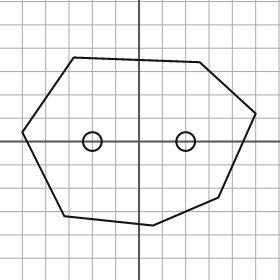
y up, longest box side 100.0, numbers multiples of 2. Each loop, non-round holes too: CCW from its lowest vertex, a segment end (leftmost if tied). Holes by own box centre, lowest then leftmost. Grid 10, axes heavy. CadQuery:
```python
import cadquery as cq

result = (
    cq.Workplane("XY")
    .moveTo(6.0, -36.0)
    .lineTo(34.0, -24.0)
    .lineTo(50.0, 12.0)
    .lineTo(26.0, 34.0)
    .lineTo(-28.0, 36.0)
    .lineTo(-50.0, 4.0)
    .lineTo(-32.0, -32.0)
    .close()
    .moveTo(-20.0, 0.0)
    .circle(4.0)
    .moveTo(20.0, 0.0)
    .circle(4.0)
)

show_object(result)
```